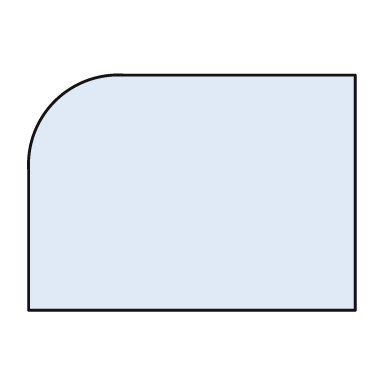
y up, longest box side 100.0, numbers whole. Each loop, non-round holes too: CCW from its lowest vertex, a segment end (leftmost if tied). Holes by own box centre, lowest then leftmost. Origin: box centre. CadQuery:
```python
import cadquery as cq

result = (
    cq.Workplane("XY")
    .moveTo(-50.0, -36.0)
    .lineTo(50.0, -36.0)
    .lineTo(50.0, 36.0)
    .lineTo(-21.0, 36.0)
    .threePointArc((-42.0, 28.0), (-50.0, 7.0))
    .close()
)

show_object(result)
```